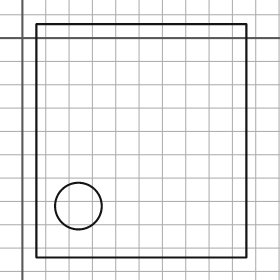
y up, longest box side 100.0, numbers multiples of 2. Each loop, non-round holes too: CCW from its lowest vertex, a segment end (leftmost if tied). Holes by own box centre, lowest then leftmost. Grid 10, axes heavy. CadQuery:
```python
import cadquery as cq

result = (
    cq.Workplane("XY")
    .moveTo(6.0, -94.0)
    .lineTo(96.0, -94.0)
    .lineTo(96.0, 6.0)
    .lineTo(6.0, 6.0)
    .close()
    .moveTo(24.0, -72.0)
    .circle(10.0)
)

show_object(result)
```